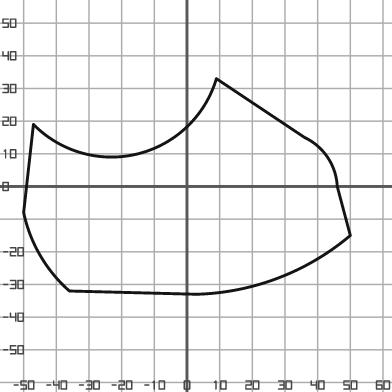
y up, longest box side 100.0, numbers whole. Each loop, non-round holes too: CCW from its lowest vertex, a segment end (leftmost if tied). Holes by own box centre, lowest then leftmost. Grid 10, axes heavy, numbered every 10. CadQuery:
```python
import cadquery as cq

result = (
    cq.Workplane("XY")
    .moveTo(3.0, -33.0)
    .threePointArc((28.0, -28.0), (50.0, -15.0))
    .lineTo(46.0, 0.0)
    .threePointArc((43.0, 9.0), (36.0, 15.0))
    .lineTo(9.0, 33.0)
    .threePointArc((-15.0, 10.0), (-47.0, 19.0))
    .lineTo(-50.0, -8.0)
    .threePointArc((-45.0, -21.0), (-36.0, -32.0))
    .close()
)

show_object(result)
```